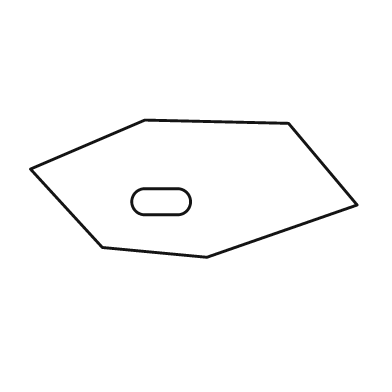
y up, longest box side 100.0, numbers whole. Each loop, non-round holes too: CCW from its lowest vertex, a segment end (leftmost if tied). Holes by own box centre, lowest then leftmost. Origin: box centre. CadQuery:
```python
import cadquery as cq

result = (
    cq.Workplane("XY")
    .moveTo(4.0, -21.0)
    .lineTo(50.0, -5.0)
    .lineTo(29.0, 20.0)
    .lineTo(-15.0, 21.0)
    .lineTo(-50.0, 6.0)
    .lineTo(-28.0, -18.0)
    .close()
    .moveTo(-15.0, -8.0)
    .lineTo(-5.0, -8.0)
    .threePointArc((-1.0, -4.0), (-5.0, 0.0))
    .lineTo(-15.0, 0.0)
    .threePointArc((-19.0, -4.0), (-15.0, -8.0))
    .close()
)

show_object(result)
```